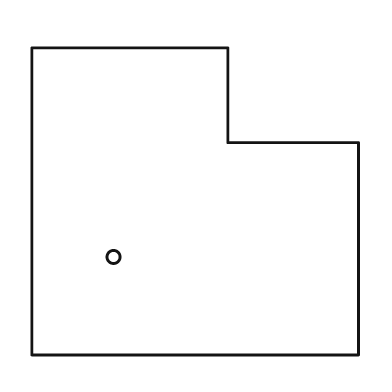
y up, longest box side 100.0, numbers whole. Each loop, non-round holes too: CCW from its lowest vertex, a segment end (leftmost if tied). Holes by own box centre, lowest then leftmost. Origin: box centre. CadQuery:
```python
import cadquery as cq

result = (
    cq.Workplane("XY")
    .moveTo(-50.0, -47.0)
    .lineTo(50.0, -47.0)
    .lineTo(50.0, 18.0)
    .lineTo(10.0, 18.0)
    .lineTo(10.0, 47.0)
    .lineTo(-50.0, 47.0)
    .close()
    .moveTo(-25.0, -17.0)
    .circle(2.0)
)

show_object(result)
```